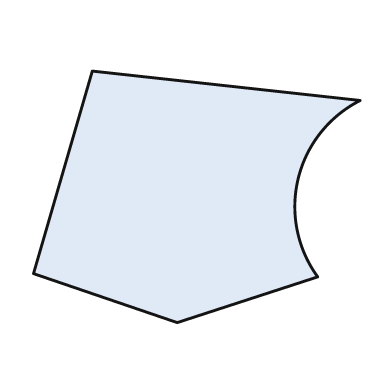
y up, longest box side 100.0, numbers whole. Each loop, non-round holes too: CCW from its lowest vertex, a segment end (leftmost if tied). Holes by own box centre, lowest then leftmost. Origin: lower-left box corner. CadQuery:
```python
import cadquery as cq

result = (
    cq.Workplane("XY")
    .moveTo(44.0, 0.0)
    .lineTo(87.0, 14.0)
    .threePointArc((81.0, 44.0), (100.0, 68.0))
    .lineTo(18.0, 77.0)
    .lineTo(0.0, 15.0)
    .close()
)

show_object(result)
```